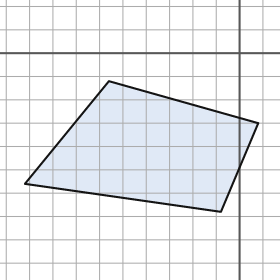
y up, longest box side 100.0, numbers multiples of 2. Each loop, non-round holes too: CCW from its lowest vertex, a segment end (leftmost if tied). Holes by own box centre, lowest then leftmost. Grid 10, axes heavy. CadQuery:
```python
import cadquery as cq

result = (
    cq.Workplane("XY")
    .moveTo(-8.0, -68.0)
    .lineTo(8.0, -30.0)
    .lineTo(-56.0, -12.0)
    .lineTo(-92.0, -56.0)
    .close()
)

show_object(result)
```